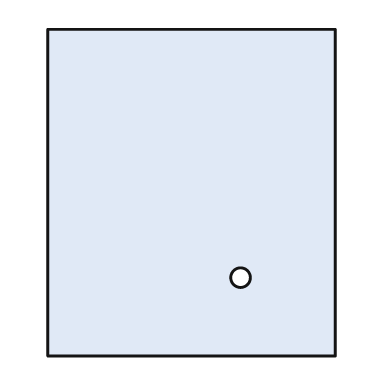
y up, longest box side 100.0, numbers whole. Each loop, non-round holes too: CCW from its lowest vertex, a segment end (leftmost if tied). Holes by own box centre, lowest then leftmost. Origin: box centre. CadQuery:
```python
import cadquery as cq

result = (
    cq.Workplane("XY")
    .moveTo(-44.0, -50.0)
    .lineTo(44.0, -50.0)
    .lineTo(44.0, 50.0)
    .lineTo(-44.0, 50.0)
    .close()
    .moveTo(15.0, -26.0)
    .circle(3.0)
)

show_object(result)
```